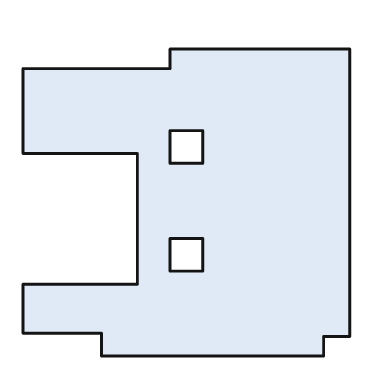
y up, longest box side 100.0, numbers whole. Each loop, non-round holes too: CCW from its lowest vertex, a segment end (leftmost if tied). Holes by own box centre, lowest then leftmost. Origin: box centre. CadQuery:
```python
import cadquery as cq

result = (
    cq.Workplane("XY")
    .moveTo(-26.0, -47.0)
    .lineTo(42.0, -47.0)
    .lineTo(42.0, -41.0)
    .lineTo(50.0, -41.0)
    .lineTo(50.0, 47.0)
    .lineTo(-5.0, 47.0)
    .lineTo(-5.0, 41.0)
    .lineTo(-50.0, 41.0)
    .lineTo(-50.0, 15.0)
    .lineTo(-15.0, 15.0)
    .lineTo(-15.0, -25.0)
    .lineTo(-50.0, -25.0)
    .lineTo(-50.0, -40.0)
    .lineTo(-26.0, -40.0)
    .close()
    .moveTo(-5.0, -21.0)
    .lineTo(5.0, -21.0)
    .lineTo(5.0, -11.0)
    .lineTo(-5.0, -11.0)
    .close()
    .moveTo(-5.0, 12.0)
    .lineTo(5.0, 12.0)
    .lineTo(5.0, 22.0)
    .lineTo(-5.0, 22.0)
    .close()
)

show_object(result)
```